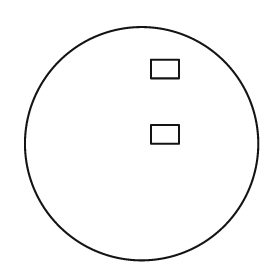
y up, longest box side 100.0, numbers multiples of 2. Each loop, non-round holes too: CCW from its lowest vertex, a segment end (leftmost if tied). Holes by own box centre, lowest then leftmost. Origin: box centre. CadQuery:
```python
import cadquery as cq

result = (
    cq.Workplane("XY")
    .moveTo(0.0, 0.0)
    .circle(50.0)
    .moveTo(4.0, 0.0)
    .lineTo(16.0, 0.0)
    .lineTo(16.0, 8.0)
    .lineTo(4.0, 8.0)
    .close()
    .moveTo(4.0, 28.0)
    .lineTo(16.0, 28.0)
    .lineTo(16.0, 36.0)
    .lineTo(4.0, 36.0)
    .close()
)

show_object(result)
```